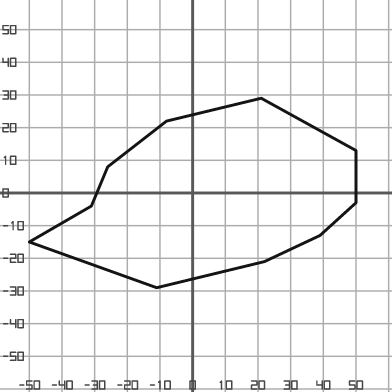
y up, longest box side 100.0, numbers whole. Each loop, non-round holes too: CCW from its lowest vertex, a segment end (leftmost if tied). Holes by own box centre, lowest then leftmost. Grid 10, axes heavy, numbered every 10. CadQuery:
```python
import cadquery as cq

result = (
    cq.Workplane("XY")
    .moveTo(-11.0, -29.0)
    .lineTo(22.0, -21.0)
    .lineTo(39.0, -13.0)
    .lineTo(50.0, -3.0)
    .lineTo(50.0, 13.0)
    .lineTo(21.0, 29.0)
    .lineTo(-8.0, 22.0)
    .lineTo(-26.0, 8.0)
    .lineTo(-31.0, -4.0)
    .lineTo(-50.0, -15.0)
    .close()
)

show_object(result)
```